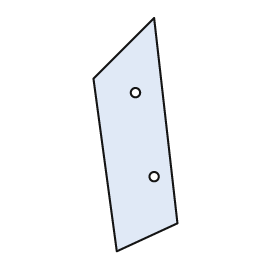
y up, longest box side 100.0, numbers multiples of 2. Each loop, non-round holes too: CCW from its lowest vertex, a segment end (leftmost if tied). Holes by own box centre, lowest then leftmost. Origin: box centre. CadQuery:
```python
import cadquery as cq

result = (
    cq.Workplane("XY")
    .moveTo(-8.0, -50.0)
    .lineTo(18.0, -38.0)
    .lineTo(8.0, 50.0)
    .lineTo(-18.0, 24.0)
    .close()
    .moveTo(8.0, -18.0)
    .circle(2.0)
    .moveTo(0.0, 18.0)
    .circle(2.0)
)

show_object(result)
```